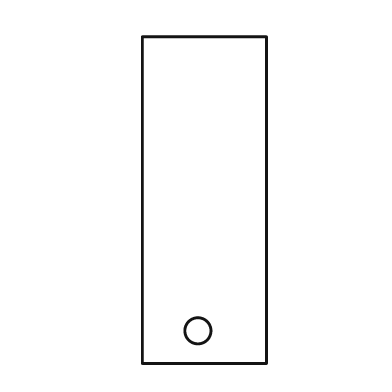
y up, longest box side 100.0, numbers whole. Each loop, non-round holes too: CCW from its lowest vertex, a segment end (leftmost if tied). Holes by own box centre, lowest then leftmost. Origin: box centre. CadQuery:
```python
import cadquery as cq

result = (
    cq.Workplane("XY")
    .moveTo(-19.0, -50.0)
    .lineTo(19.0, -50.0)
    .lineTo(19.0, 50.0)
    .lineTo(-19.0, 50.0)
    .close()
    .moveTo(-2.0, -40.0)
    .circle(4.0)
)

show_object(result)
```